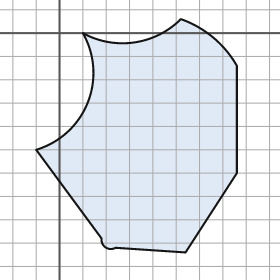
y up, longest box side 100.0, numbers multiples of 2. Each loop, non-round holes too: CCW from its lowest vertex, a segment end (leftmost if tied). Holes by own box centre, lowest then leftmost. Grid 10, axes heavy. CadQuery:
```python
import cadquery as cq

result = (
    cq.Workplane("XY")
    .moveTo(54.0, -94.0)
    .lineTo(76.0, -60.0)
    .lineTo(76.0, -14.0)
    .threePointArc((66.0, -2.0), (52.0, 6.0))
    .threePointArc((32.0, -4.0), (10.0, 0.0))
    .threePointArc((12.0, -30.0), (-10.0, -50.0))
    .lineTo(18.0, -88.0)
    .threePointArc((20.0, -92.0), (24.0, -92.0))
    .close()
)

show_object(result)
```